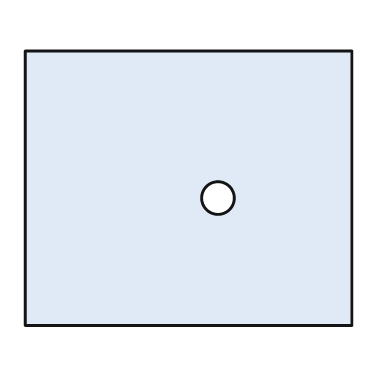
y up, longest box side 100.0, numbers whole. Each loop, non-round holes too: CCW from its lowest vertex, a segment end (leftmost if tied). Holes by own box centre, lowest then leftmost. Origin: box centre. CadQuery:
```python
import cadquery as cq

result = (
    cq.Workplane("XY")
    .moveTo(-50.0, -42.0)
    .lineTo(50.0, -42.0)
    .lineTo(50.0, 42.0)
    .lineTo(-50.0, 42.0)
    .close()
    .moveTo(9.0, -3.0)
    .circle(5.0)
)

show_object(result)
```